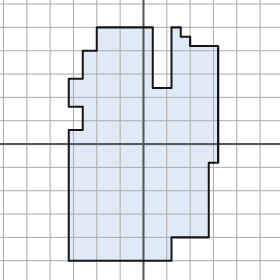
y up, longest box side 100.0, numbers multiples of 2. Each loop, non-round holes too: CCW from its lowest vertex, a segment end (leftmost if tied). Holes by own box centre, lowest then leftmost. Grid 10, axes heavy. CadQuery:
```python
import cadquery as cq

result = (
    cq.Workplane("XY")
    .moveTo(-32.0, -50.0)
    .lineTo(12.0, -50.0)
    .lineTo(12.0, -40.0)
    .lineTo(28.0, -40.0)
    .lineTo(28.0, -8.0)
    .lineTo(32.0, -8.0)
    .lineTo(32.0, 42.0)
    .lineTo(20.0, 42.0)
    .lineTo(20.0, 46.0)
    .lineTo(16.0, 46.0)
    .lineTo(16.0, 50.0)
    .lineTo(12.0, 50.0)
    .lineTo(12.0, 24.0)
    .lineTo(4.0, 24.0)
    .lineTo(4.0, 50.0)
    .lineTo(-20.0, 50.0)
    .lineTo(-20.0, 40.0)
    .lineTo(-26.0, 40.0)
    .lineTo(-26.0, 28.0)
    .lineTo(-32.0, 28.0)
    .lineTo(-32.0, 16.0)
    .lineTo(-26.0, 16.0)
    .lineTo(-26.0, 6.0)
    .lineTo(-32.0, 6.0)
    .close()
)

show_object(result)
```